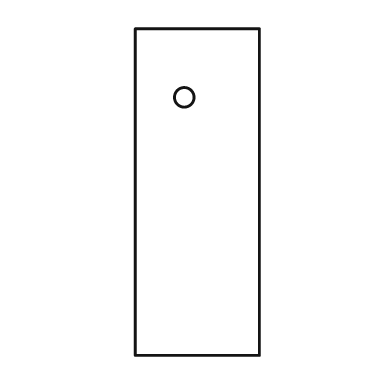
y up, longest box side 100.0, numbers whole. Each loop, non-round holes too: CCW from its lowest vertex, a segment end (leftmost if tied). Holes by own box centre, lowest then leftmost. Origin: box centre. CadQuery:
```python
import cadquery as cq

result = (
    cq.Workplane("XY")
    .moveTo(-19.0, -50.0)
    .lineTo(19.0, -50.0)
    .lineTo(19.0, 50.0)
    .lineTo(-19.0, 50.0)
    .close()
    .moveTo(-4.0, 29.0)
    .circle(3.0)
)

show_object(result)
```